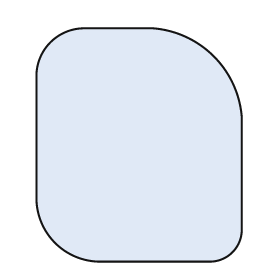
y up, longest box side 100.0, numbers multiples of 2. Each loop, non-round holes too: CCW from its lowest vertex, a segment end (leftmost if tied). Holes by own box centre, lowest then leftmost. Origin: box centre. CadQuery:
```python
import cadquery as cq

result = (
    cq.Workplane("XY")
    .moveTo(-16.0, -50.0)
    .lineTo(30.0, -50.0)
    .threePointArc((40.0, -46.0), (44.0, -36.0))
    .lineTo(44.0, 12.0)
    .threePointArc((32.0, 38.0), (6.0, 50.0))
    .lineTo(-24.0, 50.0)
    .threePointArc((-38.0, 44.0), (-44.0, 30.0))
    .lineTo(-44.0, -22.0)
    .threePointArc((-36.0, -42.0), (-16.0, -50.0))
    .close()
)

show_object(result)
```